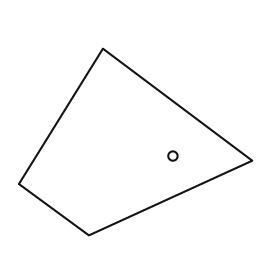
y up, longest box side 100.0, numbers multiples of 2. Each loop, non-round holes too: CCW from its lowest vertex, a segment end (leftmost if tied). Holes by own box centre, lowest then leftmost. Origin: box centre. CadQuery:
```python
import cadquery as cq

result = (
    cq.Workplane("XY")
    .moveTo(-20.0, -40.0)
    .lineTo(50.0, -8.0)
    .lineTo(-14.0, 40.0)
    .lineTo(-50.0, -18.0)
    .close()
    .moveTo(16.0, -6.0)
    .circle(2.0)
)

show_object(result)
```